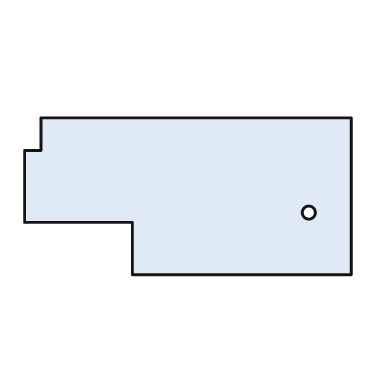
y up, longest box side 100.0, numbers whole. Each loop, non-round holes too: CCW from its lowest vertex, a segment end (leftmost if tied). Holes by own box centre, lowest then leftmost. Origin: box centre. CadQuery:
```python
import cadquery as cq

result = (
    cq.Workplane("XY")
    .moveTo(-17.0, -24.0)
    .lineTo(50.0, -24.0)
    .lineTo(50.0, 24.0)
    .lineTo(-45.0, 24.0)
    .lineTo(-45.0, 14.0)
    .lineTo(-50.0, 14.0)
    .lineTo(-50.0, -8.0)
    .lineTo(-17.0, -8.0)
    .close()
    .moveTo(37.0, -5.0)
    .circle(2.0)
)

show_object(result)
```